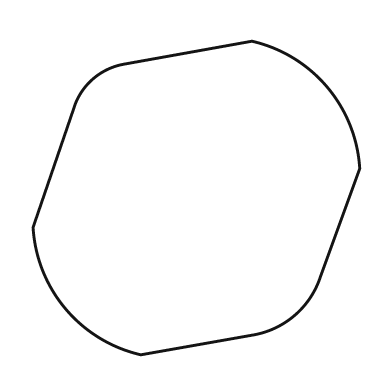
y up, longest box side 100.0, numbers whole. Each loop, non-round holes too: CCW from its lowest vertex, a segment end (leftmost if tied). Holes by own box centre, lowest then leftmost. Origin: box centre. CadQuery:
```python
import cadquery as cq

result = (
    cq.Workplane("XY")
    .moveTo(-17.0, -48.0)
    .lineTo(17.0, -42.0)
    .threePointArc((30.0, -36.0), (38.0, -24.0))
    .lineTo(50.0, 9.0)
    .threePointArc((40.0, 34.0), (17.0, 48.0))
    .lineTo(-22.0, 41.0)
    .threePointArc((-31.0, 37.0), (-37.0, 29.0))
    .lineTo(-50.0, -9.0)
    .threePointArc((-40.0, -34.0), (-17.0, -48.0))
    .close()
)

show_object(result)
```